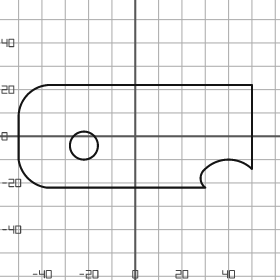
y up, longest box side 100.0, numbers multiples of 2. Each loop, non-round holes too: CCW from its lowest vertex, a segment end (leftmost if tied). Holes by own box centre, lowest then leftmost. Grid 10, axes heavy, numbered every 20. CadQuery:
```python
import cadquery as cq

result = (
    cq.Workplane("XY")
    .moveTo(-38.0, -22.0)
    .lineTo(30.0, -22.0)
    .threePointArc((28.0, -18.0), (30.0, -14.0))
    .threePointArc((40.0, -10.0), (50.0, -14.0))
    .lineTo(50.0, 22.0)
    .lineTo(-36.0, 22.0)
    .threePointArc((-46.0, 18.0), (-50.0, 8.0))
    .lineTo(-50.0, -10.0)
    .threePointArc((-46.0, -18.0), (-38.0, -22.0))
    .close()
    .moveTo(-22.0, -4.0)
    .circle(6.0)
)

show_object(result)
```